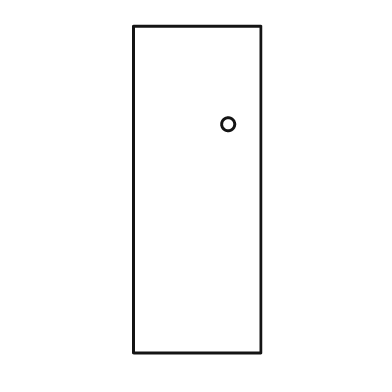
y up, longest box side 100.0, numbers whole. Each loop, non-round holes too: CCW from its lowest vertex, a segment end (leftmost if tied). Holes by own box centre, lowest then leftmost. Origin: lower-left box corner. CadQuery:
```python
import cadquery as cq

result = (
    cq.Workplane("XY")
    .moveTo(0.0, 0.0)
    .lineTo(39.0, 0.0)
    .lineTo(39.0, 100.0)
    .lineTo(0.0, 100.0)
    .close()
    .moveTo(29.0, 70.0)
    .circle(2.0)
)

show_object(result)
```